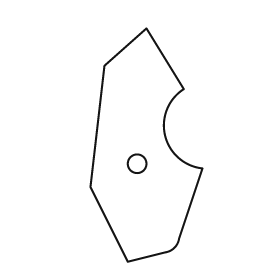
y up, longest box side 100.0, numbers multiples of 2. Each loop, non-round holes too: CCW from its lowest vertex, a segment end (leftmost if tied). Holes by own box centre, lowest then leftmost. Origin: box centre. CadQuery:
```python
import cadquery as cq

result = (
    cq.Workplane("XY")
    .moveTo(-8.0, -50.0)
    .lineTo(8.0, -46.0)
    .threePointArc((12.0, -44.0), (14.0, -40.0))
    .lineTo(24.0, -10.0)
    .threePointArc((8.0, 4.0), (16.0, 24.0))
    .lineTo(0.0, 50.0)
    .lineTo(-18.0, 34.0)
    .lineTo(-24.0, -18.0)
    .close()
    .moveTo(-4.0, -8.0)
    .circle(4.0)
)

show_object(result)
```